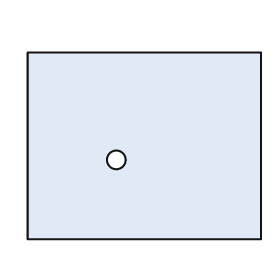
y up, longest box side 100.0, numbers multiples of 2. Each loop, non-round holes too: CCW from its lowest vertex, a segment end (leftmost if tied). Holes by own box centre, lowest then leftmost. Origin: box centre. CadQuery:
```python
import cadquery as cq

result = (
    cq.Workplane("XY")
    .moveTo(-50.0, -40.0)
    .lineTo(50.0, -40.0)
    .lineTo(50.0, 40.0)
    .lineTo(-50.0, 40.0)
    .close()
    .moveTo(-12.0, -6.0)
    .circle(4.0)
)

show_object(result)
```